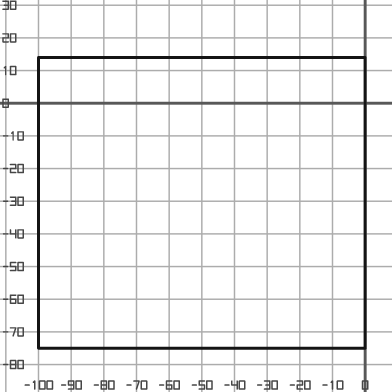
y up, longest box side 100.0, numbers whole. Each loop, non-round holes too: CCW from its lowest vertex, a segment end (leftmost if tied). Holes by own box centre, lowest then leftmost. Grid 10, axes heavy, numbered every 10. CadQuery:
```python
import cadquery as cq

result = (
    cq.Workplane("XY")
    .moveTo(-100.0, -75.0)
    .lineTo(0.0, -75.0)
    .lineTo(0.0, 14.0)
    .lineTo(-100.0, 14.0)
    .close()
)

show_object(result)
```